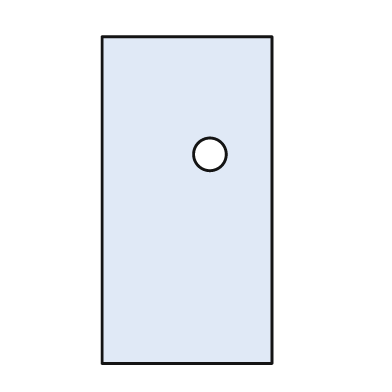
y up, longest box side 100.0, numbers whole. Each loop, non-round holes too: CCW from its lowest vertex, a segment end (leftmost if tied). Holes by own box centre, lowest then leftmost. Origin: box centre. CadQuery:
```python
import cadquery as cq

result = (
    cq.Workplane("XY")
    .moveTo(-26.0, -50.0)
    .lineTo(26.0, -50.0)
    .lineTo(26.0, 50.0)
    .lineTo(-26.0, 50.0)
    .close()
    .moveTo(7.0, 14.0)
    .circle(5.0)
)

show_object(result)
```